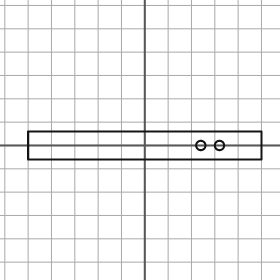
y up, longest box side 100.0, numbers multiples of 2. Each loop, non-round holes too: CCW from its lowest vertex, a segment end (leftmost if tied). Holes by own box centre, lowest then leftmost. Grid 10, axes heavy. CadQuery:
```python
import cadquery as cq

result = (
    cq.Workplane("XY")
    .moveTo(-50.0, -6.0)
    .lineTo(50.0, -6.0)
    .lineTo(50.0, 6.0)
    .lineTo(-50.0, 6.0)
    .close()
    .moveTo(24.0, 0.0)
    .circle(2.0)
    .moveTo(32.0, 0.0)
    .circle(2.0)
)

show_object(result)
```